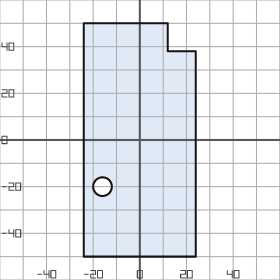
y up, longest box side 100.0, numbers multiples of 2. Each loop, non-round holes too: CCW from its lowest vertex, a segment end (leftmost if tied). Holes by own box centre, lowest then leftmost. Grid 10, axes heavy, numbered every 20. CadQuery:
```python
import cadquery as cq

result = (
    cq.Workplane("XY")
    .moveTo(-24.0, -50.0)
    .lineTo(24.0, -50.0)
    .lineTo(24.0, 38.0)
    .lineTo(12.0, 38.0)
    .lineTo(12.0, 50.0)
    .lineTo(-24.0, 50.0)
    .close()
    .moveTo(-16.0, -20.0)
    .circle(4.0)
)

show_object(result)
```